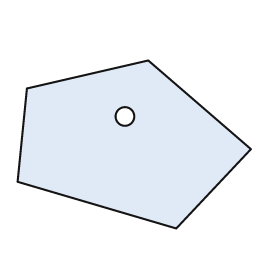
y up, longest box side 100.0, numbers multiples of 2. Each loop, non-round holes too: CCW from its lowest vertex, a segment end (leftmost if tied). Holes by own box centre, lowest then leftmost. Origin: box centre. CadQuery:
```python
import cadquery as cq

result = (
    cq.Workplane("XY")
    .moveTo(18.0, -36.0)
    .lineTo(50.0, -2.0)
    .lineTo(6.0, 36.0)
    .lineTo(-46.0, 24.0)
    .lineTo(-50.0, -16.0)
    .close()
    .moveTo(-4.0, 12.0)
    .circle(4.0)
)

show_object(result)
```